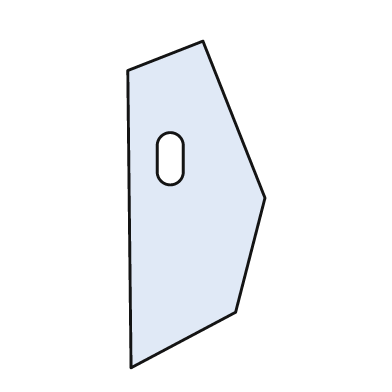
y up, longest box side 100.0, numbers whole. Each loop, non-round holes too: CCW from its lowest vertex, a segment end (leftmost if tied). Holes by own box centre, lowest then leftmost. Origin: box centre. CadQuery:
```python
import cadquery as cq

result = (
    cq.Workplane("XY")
    .moveTo(-20.0, -50.0)
    .lineTo(12.0, -33.0)
    .lineTo(21.0, 2.0)
    .lineTo(2.0, 50.0)
    .lineTo(-21.0, 41.0)
    .close()
    .moveTo(-12.0, 10.0)
    .threePointArc((-8.0, 6.0), (-4.0, 10.0))
    .lineTo(-4.0, 18.0)
    .threePointArc((-8.0, 22.0), (-12.0, 18.0))
    .close()
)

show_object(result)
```